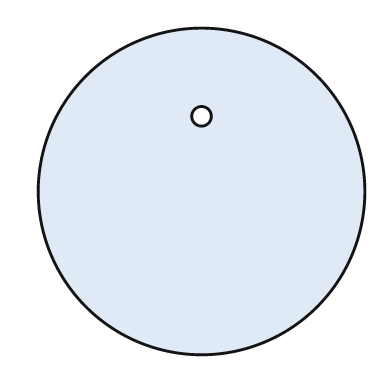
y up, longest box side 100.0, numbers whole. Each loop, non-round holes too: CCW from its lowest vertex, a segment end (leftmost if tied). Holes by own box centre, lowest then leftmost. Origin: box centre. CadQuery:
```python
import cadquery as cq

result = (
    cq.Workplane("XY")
    .moveTo(0.0, 0.0)
    .circle(50.0)
    .moveTo(0.0, 23.0)
    .circle(3.0)
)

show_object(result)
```